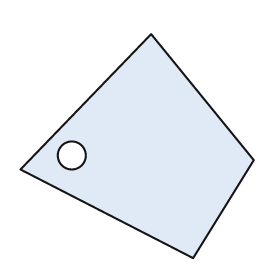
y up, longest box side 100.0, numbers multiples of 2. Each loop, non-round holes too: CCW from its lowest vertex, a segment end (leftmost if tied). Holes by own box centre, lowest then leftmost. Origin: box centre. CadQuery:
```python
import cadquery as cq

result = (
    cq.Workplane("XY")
    .moveTo(24.0, -48.0)
    .lineTo(50.0, -6.0)
    .lineTo(6.0, 48.0)
    .lineTo(-50.0, -10.0)
    .close()
    .moveTo(-28.0, -4.0)
    .circle(6.0)
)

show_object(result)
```